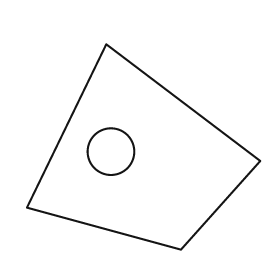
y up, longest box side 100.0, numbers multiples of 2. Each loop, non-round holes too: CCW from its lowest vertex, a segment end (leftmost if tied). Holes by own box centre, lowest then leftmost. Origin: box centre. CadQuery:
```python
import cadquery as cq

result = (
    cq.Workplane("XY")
    .moveTo(16.0, -44.0)
    .lineTo(50.0, -6.0)
    .lineTo(-16.0, 44.0)
    .lineTo(-50.0, -26.0)
    .close()
    .moveTo(-14.0, -2.0)
    .circle(10.0)
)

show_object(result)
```